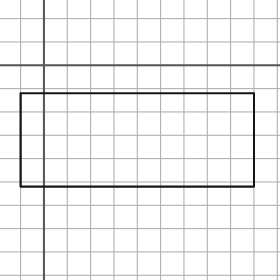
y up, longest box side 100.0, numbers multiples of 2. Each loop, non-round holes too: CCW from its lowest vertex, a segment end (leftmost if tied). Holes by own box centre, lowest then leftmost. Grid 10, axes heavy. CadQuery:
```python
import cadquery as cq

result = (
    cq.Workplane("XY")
    .moveTo(-10.0, -52.0)
    .lineTo(90.0, -52.0)
    .lineTo(90.0, -12.0)
    .lineTo(-10.0, -12.0)
    .close()
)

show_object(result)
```